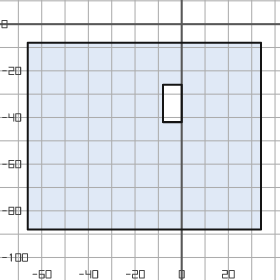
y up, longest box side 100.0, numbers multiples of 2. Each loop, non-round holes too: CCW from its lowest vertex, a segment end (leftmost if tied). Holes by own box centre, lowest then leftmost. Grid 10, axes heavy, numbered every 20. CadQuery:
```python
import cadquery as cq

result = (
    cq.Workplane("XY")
    .moveTo(-66.0, -88.0)
    .lineTo(34.0, -88.0)
    .lineTo(34.0, -8.0)
    .lineTo(-66.0, -8.0)
    .close()
    .moveTo(-8.0, -42.0)
    .lineTo(0.0, -42.0)
    .lineTo(0.0, -26.0)
    .lineTo(-8.0, -26.0)
    .close()
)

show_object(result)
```